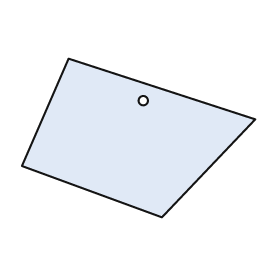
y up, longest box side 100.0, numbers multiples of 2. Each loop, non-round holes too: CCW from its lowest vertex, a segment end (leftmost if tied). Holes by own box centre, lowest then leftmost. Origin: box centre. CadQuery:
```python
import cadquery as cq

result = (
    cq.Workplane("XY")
    .moveTo(10.0, -34.0)
    .lineTo(50.0, 8.0)
    .lineTo(-30.0, 34.0)
    .lineTo(-50.0, -12.0)
    .close()
    .moveTo(2.0, 16.0)
    .circle(2.0)
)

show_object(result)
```